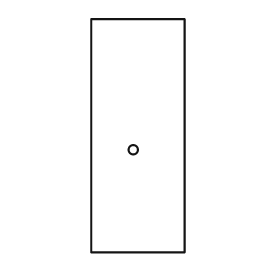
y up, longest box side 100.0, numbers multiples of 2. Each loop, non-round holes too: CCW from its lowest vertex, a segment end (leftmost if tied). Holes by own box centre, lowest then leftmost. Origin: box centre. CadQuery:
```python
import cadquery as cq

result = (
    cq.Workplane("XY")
    .moveTo(-20.0, -50.0)
    .lineTo(20.0, -50.0)
    .lineTo(20.0, 50.0)
    .lineTo(-20.0, 50.0)
    .close()
    .moveTo(-2.0, -6.0)
    .circle(2.0)
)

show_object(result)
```